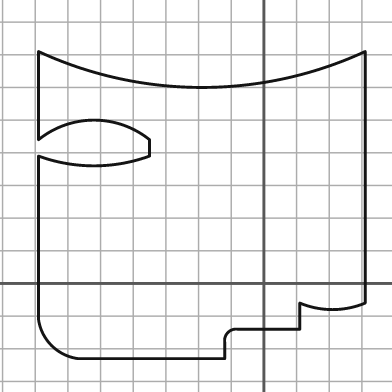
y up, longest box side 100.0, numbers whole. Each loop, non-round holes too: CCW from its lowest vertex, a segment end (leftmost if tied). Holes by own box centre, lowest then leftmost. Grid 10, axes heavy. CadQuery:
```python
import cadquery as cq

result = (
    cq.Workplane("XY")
    .moveTo(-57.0, -23.0)
    .lineTo(-12.0, -23.0)
    .lineTo(-12.0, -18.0)
    .threePointArc((-11.0, -15.0), (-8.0, -14.0))
    .lineTo(11.0, -14.0)
    .lineTo(11.0, -6.0)
    .threePointArc((21.0, -8.0), (31.0, -6.0))
    .lineTo(31.0, 71.0)
    .threePointArc((-19.0, 60.0), (-69.0, 71.0))
    .lineTo(-69.0, 44.0)
    .threePointArc((-52.0, 50.0), (-35.0, 44.0))
    .lineTo(-35.0, 39.0)
    .threePointArc((-52.0, 36.0), (-69.0, 39.0))
    .lineTo(-69.0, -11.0)
    .threePointArc((-65.0, -19.0), (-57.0, -23.0))
    .close()
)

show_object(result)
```